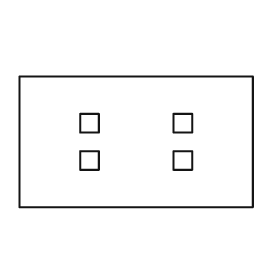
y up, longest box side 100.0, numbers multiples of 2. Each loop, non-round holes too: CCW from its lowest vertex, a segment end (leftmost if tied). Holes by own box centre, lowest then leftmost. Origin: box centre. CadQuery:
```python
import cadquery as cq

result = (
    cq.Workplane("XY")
    .moveTo(-50.0, -28.0)
    .lineTo(50.0, -28.0)
    .lineTo(50.0, 28.0)
    .lineTo(-50.0, 28.0)
    .close()
    .moveTo(-24.0, -12.0)
    .lineTo(-16.0, -12.0)
    .lineTo(-16.0, -4.0)
    .lineTo(-24.0, -4.0)
    .close()
    .moveTo(16.0, -12.0)
    .lineTo(24.0, -12.0)
    .lineTo(24.0, -4.0)
    .lineTo(16.0, -4.0)
    .close()
    .moveTo(-24.0, 4.0)
    .lineTo(-16.0, 4.0)
    .lineTo(-16.0, 12.0)
    .lineTo(-24.0, 12.0)
    .close()
    .moveTo(16.0, 4.0)
    .lineTo(24.0, 4.0)
    .lineTo(24.0, 12.0)
    .lineTo(16.0, 12.0)
    .close()
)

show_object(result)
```